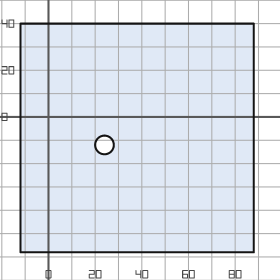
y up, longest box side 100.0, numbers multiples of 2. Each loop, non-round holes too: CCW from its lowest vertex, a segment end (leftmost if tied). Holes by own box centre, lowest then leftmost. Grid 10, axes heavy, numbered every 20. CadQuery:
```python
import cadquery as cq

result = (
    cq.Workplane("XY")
    .moveTo(-12.0, -58.0)
    .lineTo(88.0, -58.0)
    .lineTo(88.0, 40.0)
    .lineTo(-12.0, 40.0)
    .close()
    .moveTo(24.0, -12.0)
    .circle(4.0)
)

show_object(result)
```